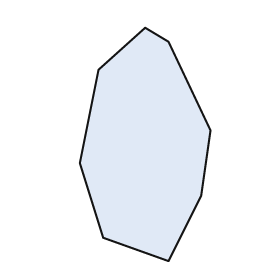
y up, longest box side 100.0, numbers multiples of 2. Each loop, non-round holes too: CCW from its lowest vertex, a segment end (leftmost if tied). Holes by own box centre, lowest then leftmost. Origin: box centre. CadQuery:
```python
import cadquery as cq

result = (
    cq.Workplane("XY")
    .moveTo(10.0, -50.0)
    .lineTo(24.0, -22.0)
    .lineTo(28.0, 6.0)
    .lineTo(10.0, 44.0)
    .lineTo(0.0, 50.0)
    .lineTo(-20.0, 32.0)
    .lineTo(-28.0, -8.0)
    .lineTo(-18.0, -40.0)
    .close()
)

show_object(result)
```